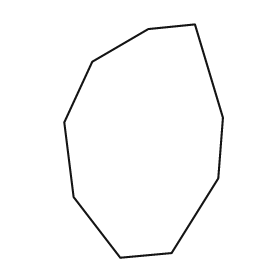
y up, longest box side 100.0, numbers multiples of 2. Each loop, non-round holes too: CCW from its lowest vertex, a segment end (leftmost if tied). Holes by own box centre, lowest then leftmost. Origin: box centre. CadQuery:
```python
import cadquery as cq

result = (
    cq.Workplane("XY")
    .moveTo(-10.0, -50.0)
    .lineTo(12.0, -48.0)
    .lineTo(32.0, -16.0)
    .lineTo(34.0, 10.0)
    .lineTo(22.0, 50.0)
    .lineTo(2.0, 48.0)
    .lineTo(-22.0, 34.0)
    .lineTo(-34.0, 8.0)
    .lineTo(-30.0, -24.0)
    .close()
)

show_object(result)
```